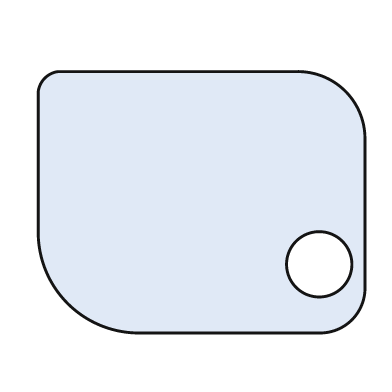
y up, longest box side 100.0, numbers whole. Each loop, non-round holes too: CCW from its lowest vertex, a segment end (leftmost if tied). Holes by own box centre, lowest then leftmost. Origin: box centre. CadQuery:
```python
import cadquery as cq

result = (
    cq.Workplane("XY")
    .moveTo(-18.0, -40.0)
    .lineTo(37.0, -40.0)
    .threePointArc((46.0, -36.0), (50.0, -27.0))
    .lineTo(50.0, 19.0)
    .threePointArc((44.0, 34.0), (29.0, 40.0))
    .lineTo(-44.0, 40.0)
    .threePointArc((-48.0, 38.0), (-50.0, 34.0))
    .lineTo(-50.0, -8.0)
    .threePointArc((-41.0, -31.0), (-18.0, -40.0))
    .close()
    .moveTo(36.0, -19.0)
    .circle(10.0)
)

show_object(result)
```